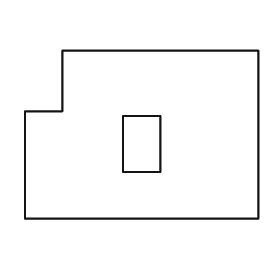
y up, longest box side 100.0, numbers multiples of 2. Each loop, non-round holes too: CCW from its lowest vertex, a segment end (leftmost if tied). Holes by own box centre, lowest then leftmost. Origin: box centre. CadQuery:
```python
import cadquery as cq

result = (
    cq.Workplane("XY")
    .moveTo(-50.0, -36.0)
    .lineTo(50.0, -36.0)
    .lineTo(50.0, 36.0)
    .lineTo(-34.0, 36.0)
    .lineTo(-34.0, 10.0)
    .lineTo(-50.0, 10.0)
    .close()
    .moveTo(-8.0, -16.0)
    .lineTo(8.0, -16.0)
    .lineTo(8.0, 8.0)
    .lineTo(-8.0, 8.0)
    .close()
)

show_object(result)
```